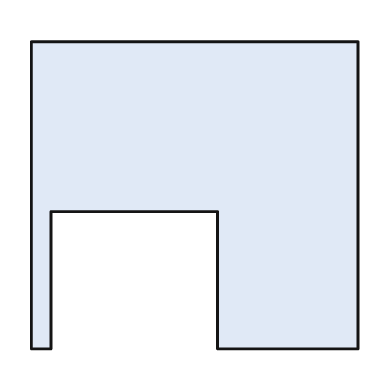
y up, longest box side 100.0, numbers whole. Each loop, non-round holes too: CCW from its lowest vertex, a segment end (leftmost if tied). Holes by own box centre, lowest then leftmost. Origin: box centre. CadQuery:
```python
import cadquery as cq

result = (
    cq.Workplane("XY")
    .moveTo(-50.0, -47.0)
    .lineTo(-44.0, -47.0)
    .lineTo(-44.0, -5.0)
    .lineTo(7.0, -5.0)
    .lineTo(7.0, -47.0)
    .lineTo(50.0, -47.0)
    .lineTo(50.0, 47.0)
    .lineTo(-50.0, 47.0)
    .close()
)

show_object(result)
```